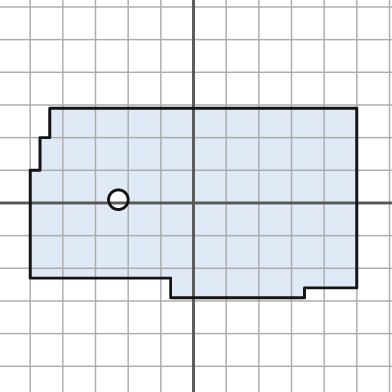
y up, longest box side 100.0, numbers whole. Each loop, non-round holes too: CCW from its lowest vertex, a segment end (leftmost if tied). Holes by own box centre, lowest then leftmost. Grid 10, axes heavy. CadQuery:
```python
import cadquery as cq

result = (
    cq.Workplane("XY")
    .moveTo(-7.0, -29.0)
    .lineTo(34.0, -29.0)
    .lineTo(34.0, -26.0)
    .lineTo(50.0, -26.0)
    .lineTo(50.0, 29.0)
    .lineTo(-44.0, 29.0)
    .lineTo(-44.0, 20.0)
    .lineTo(-47.0, 20.0)
    .lineTo(-47.0, 10.0)
    .lineTo(-50.0, 10.0)
    .lineTo(-50.0, -23.0)
    .lineTo(-7.0, -23.0)
    .close()
    .moveTo(-23.0, 1.0)
    .circle(3.0)
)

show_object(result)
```